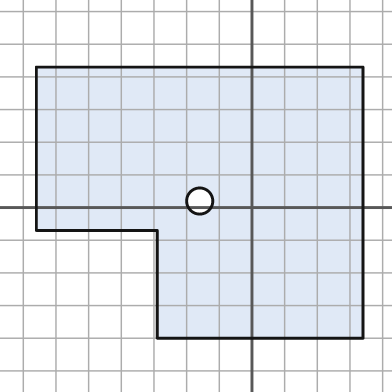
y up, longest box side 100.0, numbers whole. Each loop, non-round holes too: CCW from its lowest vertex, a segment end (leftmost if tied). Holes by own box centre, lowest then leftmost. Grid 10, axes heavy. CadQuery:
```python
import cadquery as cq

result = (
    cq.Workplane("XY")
    .moveTo(-29.0, -40.0)
    .lineTo(34.0, -40.0)
    .lineTo(34.0, 43.0)
    .lineTo(-66.0, 43.0)
    .lineTo(-66.0, -7.0)
    .lineTo(-29.0, -7.0)
    .close()
    .moveTo(-16.0, 2.0)
    .circle(4.0)
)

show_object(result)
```